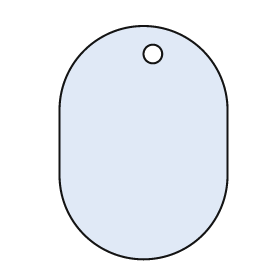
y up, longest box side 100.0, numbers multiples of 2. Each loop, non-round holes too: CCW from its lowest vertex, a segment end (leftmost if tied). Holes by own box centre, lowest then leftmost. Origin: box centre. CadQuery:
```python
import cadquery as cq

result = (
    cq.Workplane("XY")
    .moveTo(-36.0, -14.0)
    .threePointArc((0.0, -50.0), (36.0, -14.0))
    .lineTo(36.0, 14.0)
    .threePointArc((0.0, 50.0), (-36.0, 14.0))
    .close()
    .moveTo(4.0, 38.0)
    .circle(4.0)
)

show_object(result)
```